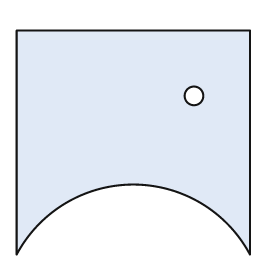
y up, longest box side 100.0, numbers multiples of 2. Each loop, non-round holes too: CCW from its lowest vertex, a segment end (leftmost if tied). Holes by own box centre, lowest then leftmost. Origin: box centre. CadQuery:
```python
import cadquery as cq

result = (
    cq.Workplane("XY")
    .moveTo(-50.0, -48.0)
    .threePointArc((0.0, -18.0), (50.0, -48.0))
    .lineTo(50.0, 48.0)
    .lineTo(-50.0, 48.0)
    .close()
    .moveTo(26.0, 20.0)
    .circle(4.0)
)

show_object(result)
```